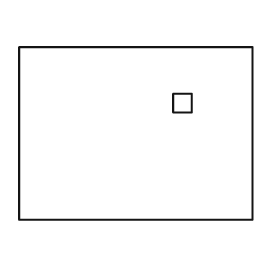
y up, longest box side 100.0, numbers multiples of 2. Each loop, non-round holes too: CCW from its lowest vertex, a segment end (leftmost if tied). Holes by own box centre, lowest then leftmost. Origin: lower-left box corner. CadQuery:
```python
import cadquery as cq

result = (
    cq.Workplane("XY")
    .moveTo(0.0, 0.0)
    .lineTo(100.0, 0.0)
    .lineTo(100.0, 74.0)
    .lineTo(0.0, 74.0)
    .close()
    .moveTo(66.0, 46.0)
    .lineTo(74.0, 46.0)
    .lineTo(74.0, 54.0)
    .lineTo(66.0, 54.0)
    .close()
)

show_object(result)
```